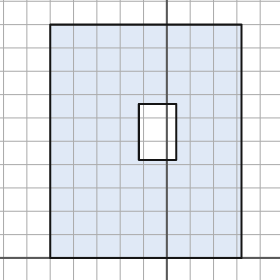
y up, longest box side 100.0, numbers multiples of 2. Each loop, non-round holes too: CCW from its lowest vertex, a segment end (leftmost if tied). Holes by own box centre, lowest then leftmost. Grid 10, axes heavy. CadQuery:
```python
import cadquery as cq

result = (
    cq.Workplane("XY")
    .moveTo(-50.0, 0.0)
    .lineTo(32.0, 0.0)
    .lineTo(32.0, 100.0)
    .lineTo(-50.0, 100.0)
    .close()
    .moveTo(-12.0, 42.0)
    .lineTo(4.0, 42.0)
    .lineTo(4.0, 66.0)
    .lineTo(-12.0, 66.0)
    .close()
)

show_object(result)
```